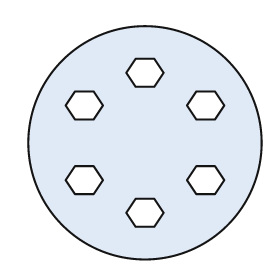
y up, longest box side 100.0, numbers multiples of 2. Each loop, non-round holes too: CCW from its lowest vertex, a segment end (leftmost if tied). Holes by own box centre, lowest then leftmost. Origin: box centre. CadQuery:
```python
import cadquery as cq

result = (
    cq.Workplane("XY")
    .moveTo(0.0, 0.0)
    .circle(50.0)
    .moveTo(-4.0, -36.0)
    .lineTo(4.0, -36.0)
    .lineTo(8.0, -30.0)
    .lineTo(4.0, -24.0)
    .lineTo(-4.0, -24.0)
    .lineTo(-8.0, -30.0)
    .close()
    .moveTo(-30.0, -22.0)
    .lineTo(-22.0, -22.0)
    .lineTo(-18.0, -16.0)
    .lineTo(-22.0, -10.0)
    .lineTo(-30.0, -10.0)
    .lineTo(-34.0, -16.0)
    .close()
    .moveTo(22.0, -22.0)
    .lineTo(30.0, -22.0)
    .lineTo(34.0, -16.0)
    .lineTo(30.0, -10.0)
    .lineTo(22.0, -10.0)
    .lineTo(18.0, -16.0)
    .close()
    .moveTo(-30.0, 10.0)
    .lineTo(-22.0, 10.0)
    .lineTo(-18.0, 16.0)
    .lineTo(-22.0, 22.0)
    .lineTo(-30.0, 22.0)
    .lineTo(-34.0, 16.0)
    .close()
    .moveTo(22.0, 10.0)
    .lineTo(30.0, 10.0)
    .lineTo(34.0, 16.0)
    .lineTo(30.0, 22.0)
    .lineTo(22.0, 22.0)
    .lineTo(18.0, 16.0)
    .close()
    .moveTo(-4.0, 24.0)
    .lineTo(4.0, 24.0)
    .lineTo(8.0, 30.0)
    .lineTo(4.0, 36.0)
    .lineTo(-4.0, 36.0)
    .lineTo(-8.0, 30.0)
    .close()
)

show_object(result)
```